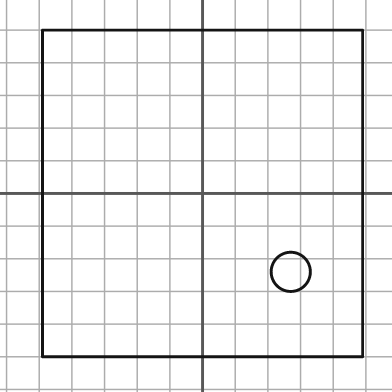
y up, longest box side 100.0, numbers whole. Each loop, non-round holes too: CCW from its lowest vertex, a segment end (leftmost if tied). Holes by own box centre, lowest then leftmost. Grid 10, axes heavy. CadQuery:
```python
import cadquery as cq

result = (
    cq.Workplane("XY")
    .moveTo(-49.0, -50.0)
    .lineTo(49.0, -50.0)
    .lineTo(49.0, 50.0)
    .lineTo(-49.0, 50.0)
    .close()
    .moveTo(27.0, -24.0)
    .circle(6.0)
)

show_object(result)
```